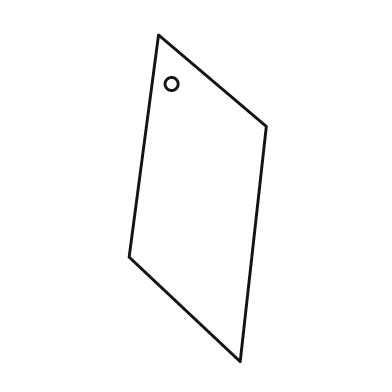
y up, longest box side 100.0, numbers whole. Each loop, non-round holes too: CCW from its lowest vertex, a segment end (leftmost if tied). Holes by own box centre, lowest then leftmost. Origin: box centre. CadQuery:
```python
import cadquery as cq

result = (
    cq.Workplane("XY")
    .moveTo(13.0, -50.0)
    .lineTo(21.0, 22.0)
    .lineTo(-12.0, 50.0)
    .lineTo(-21.0, -18.0)
    .close()
    .moveTo(-8.0, 35.0)
    .circle(2.0)
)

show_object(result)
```